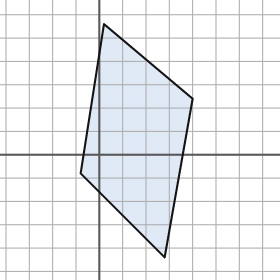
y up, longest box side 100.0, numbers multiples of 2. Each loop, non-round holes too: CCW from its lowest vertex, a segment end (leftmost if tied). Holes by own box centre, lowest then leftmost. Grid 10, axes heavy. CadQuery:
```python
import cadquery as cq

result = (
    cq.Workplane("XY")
    .moveTo(28.0, -44.0)
    .lineTo(40.0, 24.0)
    .lineTo(2.0, 56.0)
    .lineTo(-8.0, -8.0)
    .close()
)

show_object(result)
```